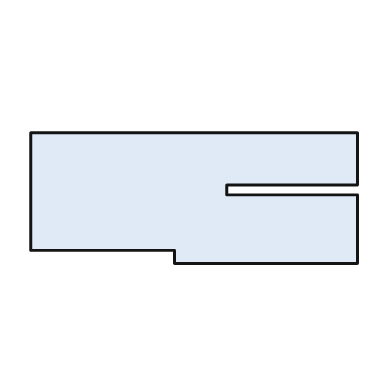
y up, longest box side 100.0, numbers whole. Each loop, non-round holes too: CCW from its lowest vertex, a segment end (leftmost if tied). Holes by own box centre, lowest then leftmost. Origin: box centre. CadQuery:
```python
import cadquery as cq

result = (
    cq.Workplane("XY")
    .moveTo(-6.0, -20.0)
    .lineTo(50.0, -20.0)
    .lineTo(50.0, 1.0)
    .lineTo(10.0, 1.0)
    .lineTo(10.0, 4.0)
    .lineTo(50.0, 4.0)
    .lineTo(50.0, 20.0)
    .lineTo(-50.0, 20.0)
    .lineTo(-50.0, -16.0)
    .lineTo(-6.0, -16.0)
    .close()
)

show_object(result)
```